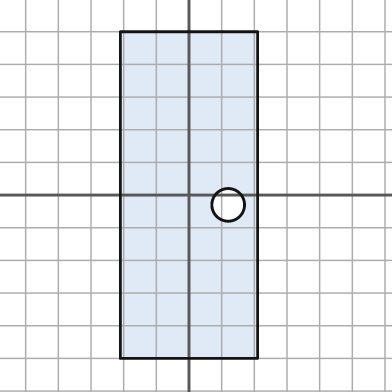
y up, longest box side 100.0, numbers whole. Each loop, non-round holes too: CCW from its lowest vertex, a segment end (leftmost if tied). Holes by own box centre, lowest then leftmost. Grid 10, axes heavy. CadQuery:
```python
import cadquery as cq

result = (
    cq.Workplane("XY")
    .moveTo(-21.0, -50.0)
    .lineTo(21.0, -50.0)
    .lineTo(21.0, 50.0)
    .lineTo(-21.0, 50.0)
    .close()
    .moveTo(12.0, -3.0)
    .circle(5.0)
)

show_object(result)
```